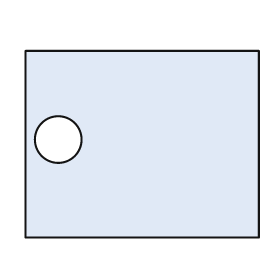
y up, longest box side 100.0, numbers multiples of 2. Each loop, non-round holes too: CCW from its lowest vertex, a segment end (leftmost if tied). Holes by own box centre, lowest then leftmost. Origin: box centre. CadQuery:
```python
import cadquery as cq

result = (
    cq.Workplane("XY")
    .moveTo(-50.0, -40.0)
    .lineTo(50.0, -40.0)
    .lineTo(50.0, 40.0)
    .lineTo(-50.0, 40.0)
    .close()
    .moveTo(-36.0, 2.0)
    .circle(10.0)
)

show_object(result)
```